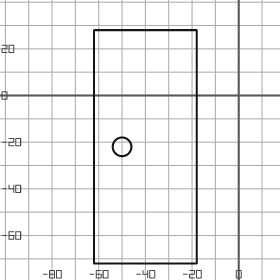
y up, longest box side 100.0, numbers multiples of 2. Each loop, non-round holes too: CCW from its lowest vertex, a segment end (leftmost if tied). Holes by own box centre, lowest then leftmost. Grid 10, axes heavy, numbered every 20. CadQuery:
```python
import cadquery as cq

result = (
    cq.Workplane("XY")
    .moveTo(-62.0, -72.0)
    .lineTo(-18.0, -72.0)
    .lineTo(-18.0, 28.0)
    .lineTo(-62.0, 28.0)
    .close()
    .moveTo(-50.0, -22.0)
    .circle(4.0)
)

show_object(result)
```